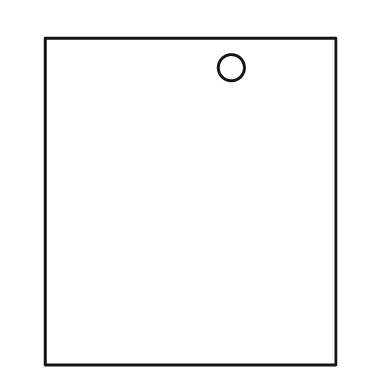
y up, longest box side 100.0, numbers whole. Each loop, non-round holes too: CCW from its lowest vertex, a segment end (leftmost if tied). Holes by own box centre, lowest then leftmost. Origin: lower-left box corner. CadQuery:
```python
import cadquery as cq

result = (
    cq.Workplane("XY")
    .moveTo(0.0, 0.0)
    .lineTo(89.0, 0.0)
    .lineTo(89.0, 100.0)
    .lineTo(0.0, 100.0)
    .close()
    .moveTo(57.0, 91.0)
    .circle(4.0)
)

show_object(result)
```